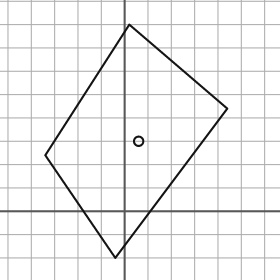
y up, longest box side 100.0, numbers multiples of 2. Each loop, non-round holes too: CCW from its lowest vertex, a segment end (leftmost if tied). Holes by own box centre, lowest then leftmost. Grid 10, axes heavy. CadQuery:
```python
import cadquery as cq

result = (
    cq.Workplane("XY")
    .moveTo(-4.0, -20.0)
    .lineTo(44.0, 44.0)
    .lineTo(2.0, 80.0)
    .lineTo(-34.0, 24.0)
    .close()
    .moveTo(6.0, 30.0)
    .circle(2.0)
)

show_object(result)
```